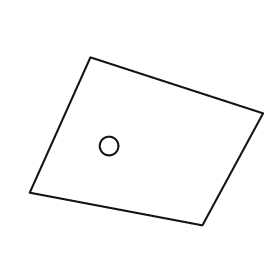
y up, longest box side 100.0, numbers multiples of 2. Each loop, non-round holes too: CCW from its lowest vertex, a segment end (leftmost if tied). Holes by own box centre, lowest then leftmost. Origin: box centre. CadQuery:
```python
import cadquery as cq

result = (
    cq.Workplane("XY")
    .moveTo(24.0, -36.0)
    .lineTo(50.0, 12.0)
    .lineTo(-24.0, 36.0)
    .lineTo(-50.0, -22.0)
    .close()
    .moveTo(-16.0, -2.0)
    .circle(4.0)
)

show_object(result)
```